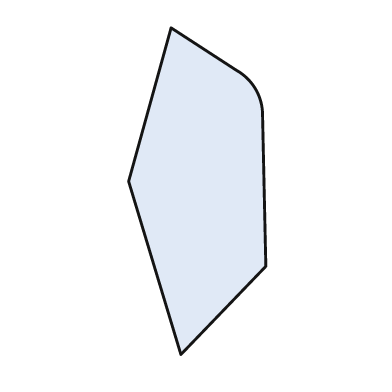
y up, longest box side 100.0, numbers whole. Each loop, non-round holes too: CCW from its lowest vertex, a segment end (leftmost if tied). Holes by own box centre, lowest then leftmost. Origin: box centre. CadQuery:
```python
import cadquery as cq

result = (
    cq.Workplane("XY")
    .moveTo(-5.0, -50.0)
    .lineTo(21.0, -23.0)
    .lineTo(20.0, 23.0)
    .threePointArc((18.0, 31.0), (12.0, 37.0))
    .lineTo(-8.0, 50.0)
    .lineTo(-21.0, 3.0)
    .close()
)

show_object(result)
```